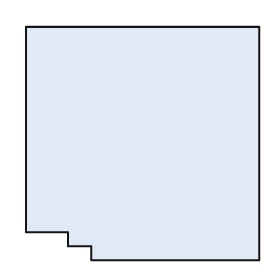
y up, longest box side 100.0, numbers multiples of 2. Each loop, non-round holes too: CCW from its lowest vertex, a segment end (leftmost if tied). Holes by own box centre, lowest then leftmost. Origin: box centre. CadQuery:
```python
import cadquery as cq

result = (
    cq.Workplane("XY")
    .moveTo(-22.0, -50.0)
    .lineTo(50.0, -50.0)
    .lineTo(50.0, 50.0)
    .lineTo(-50.0, 50.0)
    .lineTo(-50.0, -38.0)
    .lineTo(-32.0, -38.0)
    .lineTo(-32.0, -44.0)
    .lineTo(-22.0, -44.0)
    .close()
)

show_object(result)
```